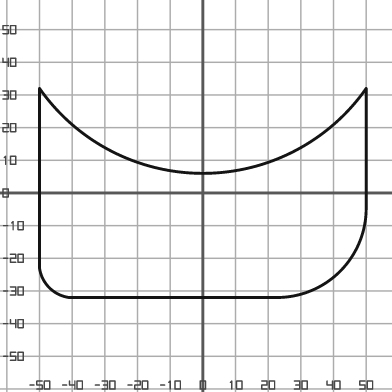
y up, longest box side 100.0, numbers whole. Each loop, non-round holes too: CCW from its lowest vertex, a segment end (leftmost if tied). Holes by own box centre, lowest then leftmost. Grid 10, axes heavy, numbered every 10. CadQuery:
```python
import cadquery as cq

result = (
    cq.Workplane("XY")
    .moveTo(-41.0, -32.0)
    .lineTo(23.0, -32.0)
    .threePointArc((42.0, -24.0), (50.0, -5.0))
    .lineTo(50.0, 32.0)
    .threePointArc((0.0, 6.0), (-50.0, 32.0))
    .lineTo(-50.0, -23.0)
    .threePointArc((-47.0, -29.0), (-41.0, -32.0))
    .close()
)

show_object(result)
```